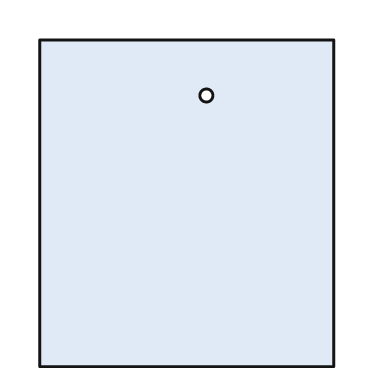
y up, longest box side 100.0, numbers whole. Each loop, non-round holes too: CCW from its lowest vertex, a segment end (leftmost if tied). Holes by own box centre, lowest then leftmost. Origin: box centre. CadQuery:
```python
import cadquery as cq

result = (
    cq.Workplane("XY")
    .moveTo(-45.0, -50.0)
    .lineTo(45.0, -50.0)
    .lineTo(45.0, 50.0)
    .lineTo(-45.0, 50.0)
    .close()
    .moveTo(6.0, 33.0)
    .circle(2.0)
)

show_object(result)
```